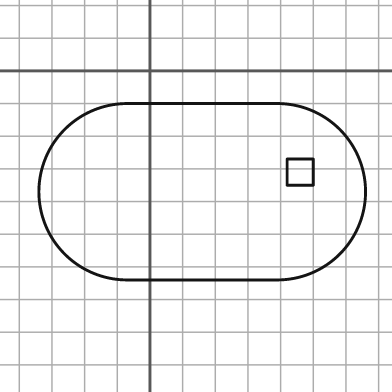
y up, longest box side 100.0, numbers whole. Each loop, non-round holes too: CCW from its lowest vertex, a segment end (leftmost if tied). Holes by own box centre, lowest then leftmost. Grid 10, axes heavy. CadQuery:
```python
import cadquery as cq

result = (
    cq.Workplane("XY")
    .moveTo(-7.0, -64.0)
    .lineTo(39.0, -64.0)
    .threePointArc((66.0, -37.0), (39.0, -10.0))
    .lineTo(-7.0, -10.0)
    .threePointArc((-34.0, -37.0), (-7.0, -64.0))
    .close()
    .moveTo(42.0, -35.0)
    .lineTo(50.0, -35.0)
    .lineTo(50.0, -27.0)
    .lineTo(42.0, -27.0)
    .close()
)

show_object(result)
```